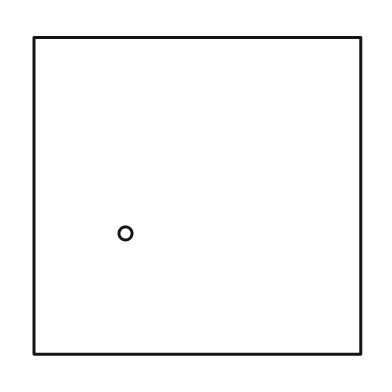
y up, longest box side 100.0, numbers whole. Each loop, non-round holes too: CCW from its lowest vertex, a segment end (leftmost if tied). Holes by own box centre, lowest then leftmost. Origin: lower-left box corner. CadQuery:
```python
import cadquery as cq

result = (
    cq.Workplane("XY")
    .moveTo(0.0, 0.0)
    .lineTo(100.0, 0.0)
    .lineTo(100.0, 97.0)
    .lineTo(0.0, 97.0)
    .close()
    .moveTo(28.0, 37.0)
    .circle(2.0)
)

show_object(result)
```